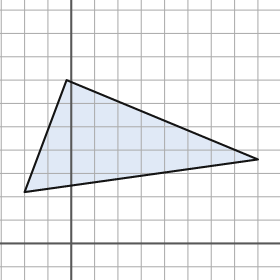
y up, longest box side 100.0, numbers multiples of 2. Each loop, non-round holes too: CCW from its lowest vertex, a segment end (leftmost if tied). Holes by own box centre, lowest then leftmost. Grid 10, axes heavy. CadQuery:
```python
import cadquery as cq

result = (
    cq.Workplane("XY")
    .moveTo(-20.0, 22.0)
    .lineTo(80.0, 36.0)
    .lineTo(-2.0, 70.0)
    .close()
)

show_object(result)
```